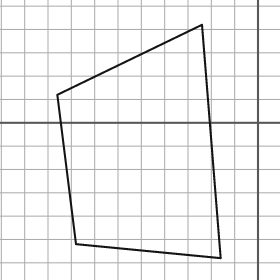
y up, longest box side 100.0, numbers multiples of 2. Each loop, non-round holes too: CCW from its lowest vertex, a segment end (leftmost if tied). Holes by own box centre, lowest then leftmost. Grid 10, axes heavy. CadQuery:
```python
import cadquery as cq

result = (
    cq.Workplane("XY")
    .moveTo(-16.0, -58.0)
    .lineTo(-24.0, 42.0)
    .lineTo(-86.0, 12.0)
    .lineTo(-78.0, -52.0)
    .close()
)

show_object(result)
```